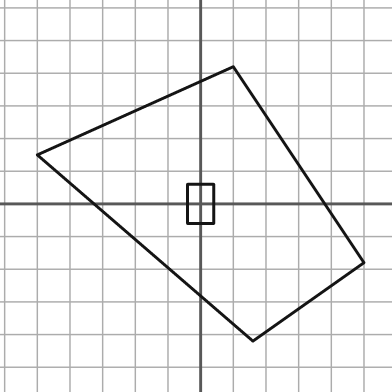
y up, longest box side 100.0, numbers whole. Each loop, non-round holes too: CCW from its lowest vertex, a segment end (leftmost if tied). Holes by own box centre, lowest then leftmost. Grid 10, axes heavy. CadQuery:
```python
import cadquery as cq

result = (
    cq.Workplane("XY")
    .moveTo(16.0, -42.0)
    .lineTo(50.0, -18.0)
    .lineTo(10.0, 42.0)
    .lineTo(-50.0, 15.0)
    .close()
    .moveTo(-4.0, -6.0)
    .lineTo(4.0, -6.0)
    .lineTo(4.0, 6.0)
    .lineTo(-4.0, 6.0)
    .close()
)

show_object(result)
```